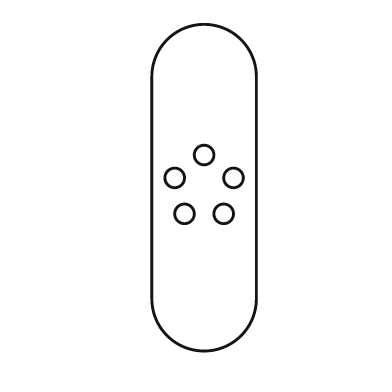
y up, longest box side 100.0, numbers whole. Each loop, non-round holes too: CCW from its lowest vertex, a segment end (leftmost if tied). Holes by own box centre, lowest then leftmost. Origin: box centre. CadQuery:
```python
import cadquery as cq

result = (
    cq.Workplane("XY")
    .moveTo(-16.0, -34.0)
    .threePointArc((0.0, -50.0), (16.0, -34.0))
    .lineTo(16.0, 34.0)
    .threePointArc((0.0, 50.0), (-16.0, 34.0))
    .close()
    .moveTo(-6.0, -8.0)
    .circle(3.0)
    .moveTo(6.0, -8.0)
    .circle(3.0)
    .moveTo(-9.0, 3.0)
    .circle(3.0)
    .moveTo(9.0, 3.0)
    .circle(3.0)
    .moveTo(0.0, 10.0)
    .circle(3.0)
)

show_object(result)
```